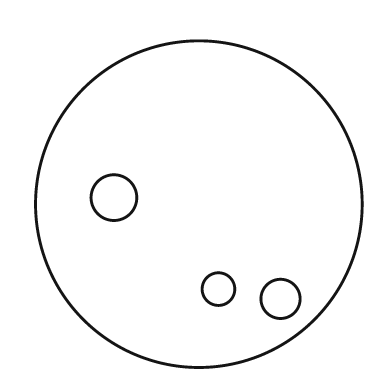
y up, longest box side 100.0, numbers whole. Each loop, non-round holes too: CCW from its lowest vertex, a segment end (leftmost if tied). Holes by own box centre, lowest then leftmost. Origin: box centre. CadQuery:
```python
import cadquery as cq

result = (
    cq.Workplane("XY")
    .moveTo(0.0, 0.0)
    .circle(50.0)
    .moveTo(25.0, -29.0)
    .circle(6.0)
    .moveTo(6.0, -26.0)
    .circle(5.0)
    .moveTo(-26.0, 2.0)
    .circle(7.0)
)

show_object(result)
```